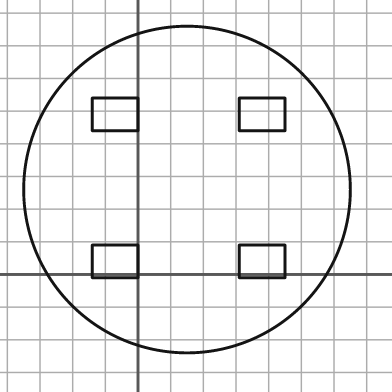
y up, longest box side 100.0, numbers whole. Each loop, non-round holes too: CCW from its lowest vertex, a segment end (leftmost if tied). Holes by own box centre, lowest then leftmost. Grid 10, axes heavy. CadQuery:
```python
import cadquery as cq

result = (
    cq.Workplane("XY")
    .moveTo(15.0, 26.0)
    .circle(50.0)
    .moveTo(-14.0, -1.0)
    .lineTo(0.0, -1.0)
    .lineTo(0.0, 9.0)
    .lineTo(-14.0, 9.0)
    .close()
    .moveTo(31.0, -1.0)
    .lineTo(45.0, -1.0)
    .lineTo(45.0, 9.0)
    .lineTo(31.0, 9.0)
    .close()
    .moveTo(-14.0, 44.0)
    .lineTo(0.0, 44.0)
    .lineTo(0.0, 54.0)
    .lineTo(-14.0, 54.0)
    .close()
    .moveTo(31.0, 44.0)
    .lineTo(45.0, 44.0)
    .lineTo(45.0, 54.0)
    .lineTo(31.0, 54.0)
    .close()
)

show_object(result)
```